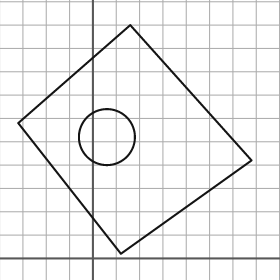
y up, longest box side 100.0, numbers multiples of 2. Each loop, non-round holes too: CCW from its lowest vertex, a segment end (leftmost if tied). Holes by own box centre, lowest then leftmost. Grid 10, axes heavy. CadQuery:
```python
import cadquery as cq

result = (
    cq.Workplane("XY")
    .moveTo(12.0, 2.0)
    .lineTo(68.0, 42.0)
    .lineTo(16.0, 100.0)
    .lineTo(-32.0, 58.0)
    .close()
    .moveTo(6.0, 52.0)
    .circle(12.0)
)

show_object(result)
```